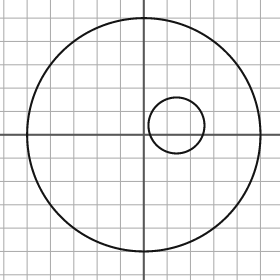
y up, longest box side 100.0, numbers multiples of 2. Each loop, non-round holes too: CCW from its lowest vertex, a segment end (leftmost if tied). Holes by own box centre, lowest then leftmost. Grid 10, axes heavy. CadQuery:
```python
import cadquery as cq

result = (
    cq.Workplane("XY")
    .moveTo(0.0, 0.0)
    .circle(50.0)
    .moveTo(14.0, 4.0)
    .circle(12.0)
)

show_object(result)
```